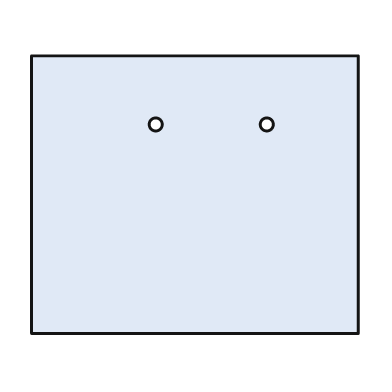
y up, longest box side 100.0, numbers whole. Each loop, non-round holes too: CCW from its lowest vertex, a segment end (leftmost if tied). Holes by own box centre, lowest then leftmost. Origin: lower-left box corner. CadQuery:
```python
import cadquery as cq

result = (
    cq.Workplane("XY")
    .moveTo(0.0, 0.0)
    .lineTo(100.0, 0.0)
    .lineTo(100.0, 85.0)
    .lineTo(0.0, 85.0)
    .close()
    .moveTo(38.0, 64.0)
    .circle(2.0)
    .moveTo(72.0, 64.0)
    .circle(2.0)
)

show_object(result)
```